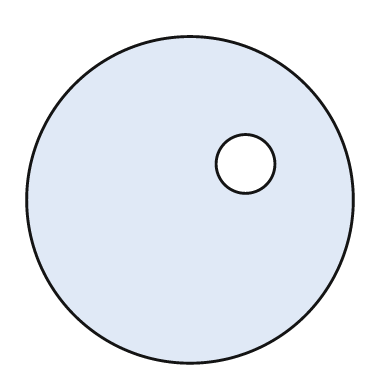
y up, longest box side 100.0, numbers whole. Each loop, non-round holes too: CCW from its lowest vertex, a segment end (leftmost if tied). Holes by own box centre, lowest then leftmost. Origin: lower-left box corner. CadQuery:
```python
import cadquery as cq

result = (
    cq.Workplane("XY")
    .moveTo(50.0, 50.0)
    .circle(50.0)
    .moveTo(67.0, 61.0)
    .circle(9.0)
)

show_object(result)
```